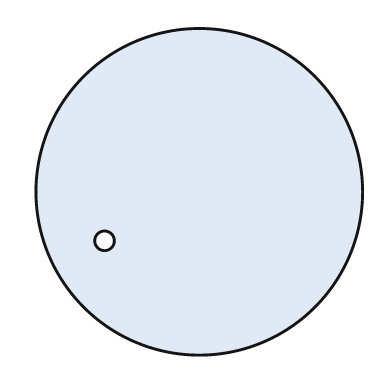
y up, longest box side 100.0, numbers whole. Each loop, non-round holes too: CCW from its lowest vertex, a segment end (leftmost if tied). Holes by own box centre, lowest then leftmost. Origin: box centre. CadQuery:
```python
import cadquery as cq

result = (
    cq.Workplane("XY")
    .moveTo(0.0, 0.0)
    .circle(50.0)
    .moveTo(-29.0, -15.0)
    .circle(3.0)
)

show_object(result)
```